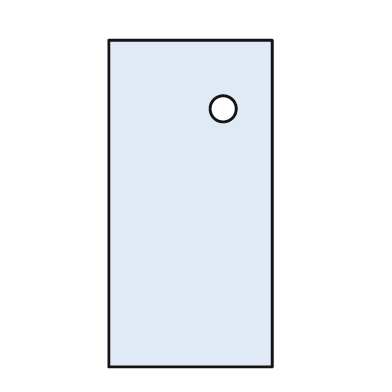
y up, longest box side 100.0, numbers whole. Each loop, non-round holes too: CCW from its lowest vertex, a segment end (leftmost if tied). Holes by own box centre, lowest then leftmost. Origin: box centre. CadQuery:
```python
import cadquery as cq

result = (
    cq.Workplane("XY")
    .moveTo(-25.0, -50.0)
    .lineTo(25.0, -50.0)
    .lineTo(25.0, 50.0)
    .lineTo(-25.0, 50.0)
    .close()
    .moveTo(10.0, 29.0)
    .circle(4.0)
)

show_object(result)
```